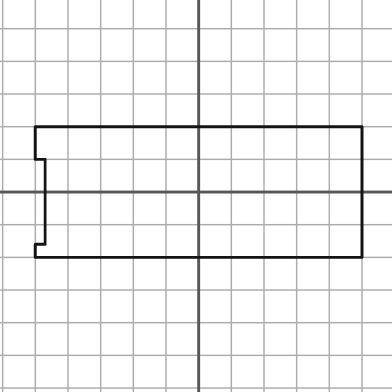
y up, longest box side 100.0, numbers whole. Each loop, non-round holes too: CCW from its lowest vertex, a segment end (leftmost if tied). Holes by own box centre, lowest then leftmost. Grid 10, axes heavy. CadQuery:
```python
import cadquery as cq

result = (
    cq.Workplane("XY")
    .moveTo(-50.0, -20.0)
    .lineTo(50.0, -20.0)
    .lineTo(50.0, 20.0)
    .lineTo(-50.0, 20.0)
    .lineTo(-50.0, 10.0)
    .lineTo(-47.0, 10.0)
    .lineTo(-47.0, -16.0)
    .lineTo(-50.0, -16.0)
    .close()
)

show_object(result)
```